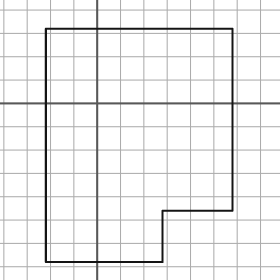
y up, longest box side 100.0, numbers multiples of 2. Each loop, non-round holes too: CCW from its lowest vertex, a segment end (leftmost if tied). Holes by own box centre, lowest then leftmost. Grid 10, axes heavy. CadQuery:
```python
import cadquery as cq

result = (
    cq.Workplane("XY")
    .moveTo(-22.0, -68.0)
    .lineTo(28.0, -68.0)
    .lineTo(28.0, -46.0)
    .lineTo(58.0, -46.0)
    .lineTo(58.0, 32.0)
    .lineTo(-22.0, 32.0)
    .close()
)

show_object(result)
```